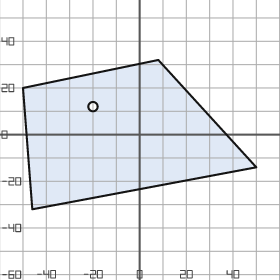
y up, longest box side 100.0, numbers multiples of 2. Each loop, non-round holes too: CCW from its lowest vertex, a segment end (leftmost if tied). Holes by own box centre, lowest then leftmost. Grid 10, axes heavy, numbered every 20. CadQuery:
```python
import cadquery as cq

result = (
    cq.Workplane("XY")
    .moveTo(-46.0, -32.0)
    .lineTo(50.0, -14.0)
    .lineTo(8.0, 32.0)
    .lineTo(-50.0, 20.0)
    .close()
    .moveTo(-20.0, 12.0)
    .circle(2.0)
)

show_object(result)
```